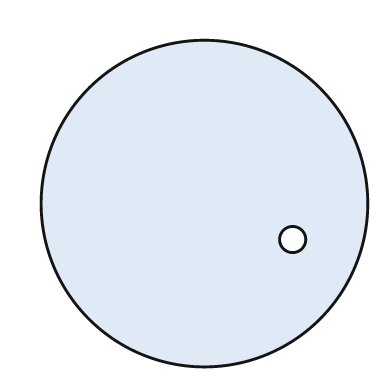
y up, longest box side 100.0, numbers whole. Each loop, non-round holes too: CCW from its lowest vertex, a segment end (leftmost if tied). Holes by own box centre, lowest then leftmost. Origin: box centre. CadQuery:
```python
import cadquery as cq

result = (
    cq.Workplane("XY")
    .moveTo(0.0, 0.0)
    .circle(50.0)
    .moveTo(27.0, -11.0)
    .circle(4.0)
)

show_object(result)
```